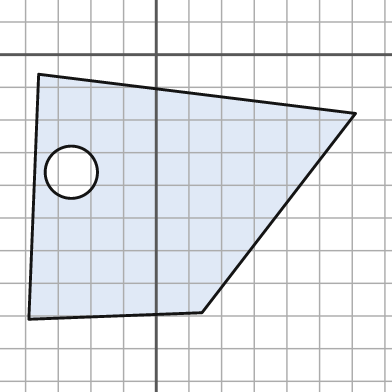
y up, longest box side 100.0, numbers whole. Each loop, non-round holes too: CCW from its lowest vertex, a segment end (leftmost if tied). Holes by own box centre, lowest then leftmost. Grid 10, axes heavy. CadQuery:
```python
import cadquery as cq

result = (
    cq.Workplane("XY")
    .moveTo(-39.0, -81.0)
    .lineTo(14.0, -79.0)
    .lineTo(61.0, -18.0)
    .lineTo(-36.0, -6.0)
    .close()
    .moveTo(-26.0, -36.0)
    .circle(8.0)
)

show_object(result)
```